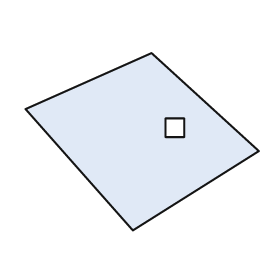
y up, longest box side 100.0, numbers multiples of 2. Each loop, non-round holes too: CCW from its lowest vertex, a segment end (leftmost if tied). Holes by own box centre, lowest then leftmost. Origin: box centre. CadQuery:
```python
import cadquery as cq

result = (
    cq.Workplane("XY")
    .moveTo(-4.0, -38.0)
    .lineTo(50.0, -4.0)
    .lineTo(4.0, 38.0)
    .lineTo(-50.0, 14.0)
    .close()
    .moveTo(10.0, 2.0)
    .lineTo(18.0, 2.0)
    .lineTo(18.0, 10.0)
    .lineTo(10.0, 10.0)
    .close()
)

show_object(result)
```